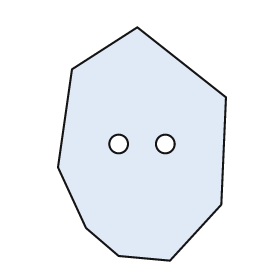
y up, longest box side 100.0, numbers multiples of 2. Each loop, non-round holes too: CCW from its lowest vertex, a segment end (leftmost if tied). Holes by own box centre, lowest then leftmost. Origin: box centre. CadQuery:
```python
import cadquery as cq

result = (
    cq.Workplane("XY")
    .moveTo(12.0, -50.0)
    .lineTo(34.0, -26.0)
    .lineTo(36.0, 20.0)
    .lineTo(-2.0, 50.0)
    .lineTo(-30.0, 32.0)
    .lineTo(-36.0, -10.0)
    .lineTo(-24.0, -36.0)
    .lineTo(-10.0, -48.0)
    .close()
    .moveTo(-10.0, 0.0)
    .circle(4.0)
    .moveTo(10.0, 0.0)
    .circle(4.0)
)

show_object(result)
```